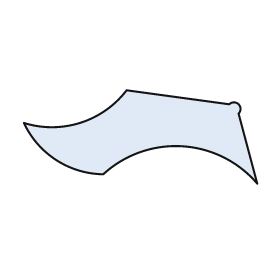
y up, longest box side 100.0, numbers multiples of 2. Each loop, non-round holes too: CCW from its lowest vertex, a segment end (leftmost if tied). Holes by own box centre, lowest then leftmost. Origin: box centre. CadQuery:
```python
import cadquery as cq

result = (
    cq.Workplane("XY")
    .moveTo(50.0, -20.0)
    .lineTo(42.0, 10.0)
    .threePointArc((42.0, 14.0), (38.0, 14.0))
    .lineTo(-6.0, 20.0)
    .threePointArc((-26.0, 6.0), (-50.0, 6.0))
    .threePointArc((-36.0, -10.0), (-16.0, -16.0))
    .threePointArc((18.0, -4.0), (50.0, -20.0))
    .close()
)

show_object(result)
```